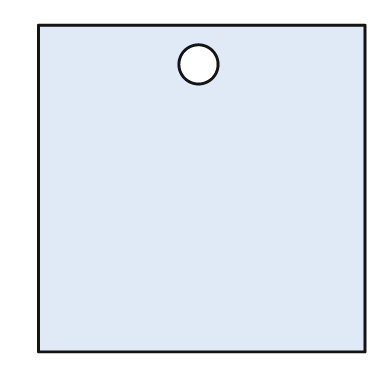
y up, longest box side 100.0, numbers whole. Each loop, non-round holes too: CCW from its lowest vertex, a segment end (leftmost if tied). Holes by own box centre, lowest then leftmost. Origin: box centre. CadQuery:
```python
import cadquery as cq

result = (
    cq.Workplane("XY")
    .moveTo(-50.0, -50.0)
    .lineTo(50.0, -50.0)
    .lineTo(50.0, 50.0)
    .lineTo(-50.0, 50.0)
    .close()
    .moveTo(-1.0, 38.0)
    .circle(6.0)
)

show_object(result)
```